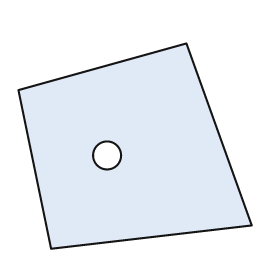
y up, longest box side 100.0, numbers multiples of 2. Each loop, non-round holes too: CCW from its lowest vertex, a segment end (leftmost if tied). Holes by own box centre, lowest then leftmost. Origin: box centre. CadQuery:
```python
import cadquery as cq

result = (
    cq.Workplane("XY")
    .moveTo(-36.0, -44.0)
    .lineTo(50.0, -34.0)
    .lineTo(22.0, 44.0)
    .lineTo(-50.0, 24.0)
    .close()
    .moveTo(-12.0, -4.0)
    .circle(6.0)
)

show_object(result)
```